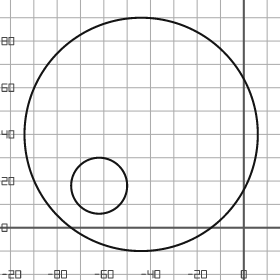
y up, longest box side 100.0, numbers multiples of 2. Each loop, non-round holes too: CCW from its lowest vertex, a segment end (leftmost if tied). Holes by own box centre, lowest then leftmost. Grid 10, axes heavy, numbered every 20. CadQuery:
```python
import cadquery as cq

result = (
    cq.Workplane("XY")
    .moveTo(-44.0, 40.0)
    .circle(50.0)
    .moveTo(-62.0, 18.0)
    .circle(12.0)
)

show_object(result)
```